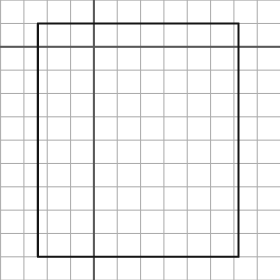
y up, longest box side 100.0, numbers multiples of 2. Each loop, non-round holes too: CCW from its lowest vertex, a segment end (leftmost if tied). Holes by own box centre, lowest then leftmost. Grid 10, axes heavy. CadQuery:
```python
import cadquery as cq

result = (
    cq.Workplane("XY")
    .moveTo(-24.0, -90.0)
    .lineTo(62.0, -90.0)
    .lineTo(62.0, 10.0)
    .lineTo(-24.0, 10.0)
    .close()
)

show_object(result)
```